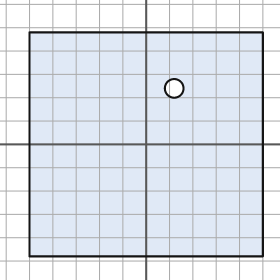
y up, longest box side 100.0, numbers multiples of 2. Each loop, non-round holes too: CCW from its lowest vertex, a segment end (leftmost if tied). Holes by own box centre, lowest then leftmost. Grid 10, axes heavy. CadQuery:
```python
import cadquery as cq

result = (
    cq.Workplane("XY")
    .moveTo(-50.0, -48.0)
    .lineTo(50.0, -48.0)
    .lineTo(50.0, 48.0)
    .lineTo(-50.0, 48.0)
    .close()
    .moveTo(12.0, 24.0)
    .circle(4.0)
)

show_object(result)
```